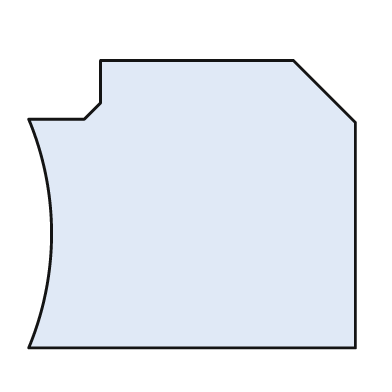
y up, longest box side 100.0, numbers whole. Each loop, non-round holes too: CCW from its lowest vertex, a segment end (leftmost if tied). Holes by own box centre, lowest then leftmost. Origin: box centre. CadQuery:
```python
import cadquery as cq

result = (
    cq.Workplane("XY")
    .moveTo(-50.0, -44.0)
    .lineTo(50.0, -44.0)
    .lineTo(50.0, 25.0)
    .lineTo(31.0, 44.0)
    .lineTo(-28.0, 44.0)
    .lineTo(-28.0, 31.0)
    .lineTo(-33.0, 26.0)
    .lineTo(-50.0, 26.0)
    .threePointArc((-43.0, -9.0), (-50.0, -44.0))
    .close()
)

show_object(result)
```